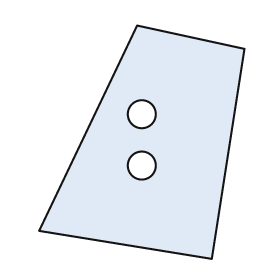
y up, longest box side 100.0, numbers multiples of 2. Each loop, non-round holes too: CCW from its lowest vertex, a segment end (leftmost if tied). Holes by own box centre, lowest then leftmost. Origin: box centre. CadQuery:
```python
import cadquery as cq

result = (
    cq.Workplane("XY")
    .moveTo(30.0, -50.0)
    .lineTo(44.0, 40.0)
    .lineTo(-2.0, 50.0)
    .lineTo(-44.0, -38.0)
    .close()
    .moveTo(0.0, -10.0)
    .circle(6.0)
    .moveTo(0.0, 12.0)
    .circle(6.0)
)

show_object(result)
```